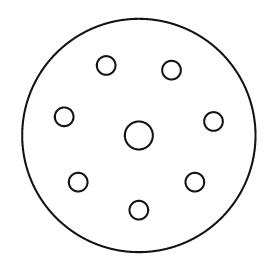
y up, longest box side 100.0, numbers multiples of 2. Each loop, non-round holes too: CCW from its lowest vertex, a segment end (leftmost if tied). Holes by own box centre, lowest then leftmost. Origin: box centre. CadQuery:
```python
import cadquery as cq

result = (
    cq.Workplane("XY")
    .moveTo(0.0, 0.0)
    .circle(50.0)
    .moveTo(0.0, -32.0)
    .circle(4.0)
    .moveTo(-26.0, -20.0)
    .circle(4.0)
    .moveTo(24.0, -20.0)
    .circle(4.0)
    .moveTo(0.0, 0.0)
    .circle(6.0)
    .moveTo(32.0, 6.0)
    .circle(4.0)
    .moveTo(-32.0, 8.0)
    .circle(4.0)
    .moveTo(14.0, 28.0)
    .circle(4.0)
    .moveTo(-14.0, 30.0)
    .circle(4.0)
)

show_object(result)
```